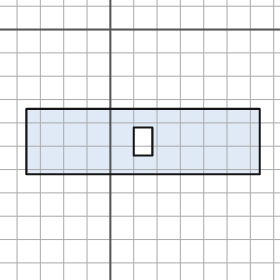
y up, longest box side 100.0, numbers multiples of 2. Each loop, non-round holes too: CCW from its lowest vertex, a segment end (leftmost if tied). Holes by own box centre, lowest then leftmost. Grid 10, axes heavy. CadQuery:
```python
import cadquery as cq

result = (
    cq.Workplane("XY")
    .moveTo(-36.0, -62.0)
    .lineTo(64.0, -62.0)
    .lineTo(64.0, -34.0)
    .lineTo(-36.0, -34.0)
    .close()
    .moveTo(10.0, -54.0)
    .lineTo(18.0, -54.0)
    .lineTo(18.0, -42.0)
    .lineTo(10.0, -42.0)
    .close()
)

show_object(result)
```